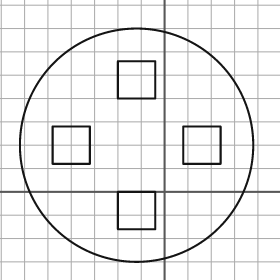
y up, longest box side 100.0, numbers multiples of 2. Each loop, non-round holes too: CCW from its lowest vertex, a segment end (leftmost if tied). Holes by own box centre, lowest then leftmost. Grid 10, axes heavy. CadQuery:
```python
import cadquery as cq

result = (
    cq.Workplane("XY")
    .moveTo(-12.0, 20.0)
    .circle(50.0)
    .moveTo(-20.0, -16.0)
    .lineTo(-4.0, -16.0)
    .lineTo(-4.0, 0.0)
    .lineTo(-20.0, 0.0)
    .close()
    .moveTo(-48.0, 12.0)
    .lineTo(-32.0, 12.0)
    .lineTo(-32.0, 28.0)
    .lineTo(-48.0, 28.0)
    .close()
    .moveTo(8.0, 12.0)
    .lineTo(24.0, 12.0)
    .lineTo(24.0, 28.0)
    .lineTo(8.0, 28.0)
    .close()
    .moveTo(-20.0, 40.0)
    .lineTo(-4.0, 40.0)
    .lineTo(-4.0, 56.0)
    .lineTo(-20.0, 56.0)
    .close()
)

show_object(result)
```